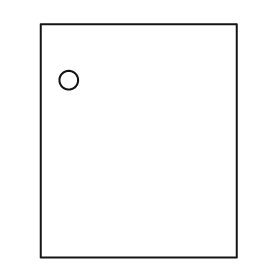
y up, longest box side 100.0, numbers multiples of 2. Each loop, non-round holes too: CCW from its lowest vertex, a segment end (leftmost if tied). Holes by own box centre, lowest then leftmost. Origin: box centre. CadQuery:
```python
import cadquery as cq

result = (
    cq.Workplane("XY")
    .moveTo(-42.0, -50.0)
    .lineTo(42.0, -50.0)
    .lineTo(42.0, 50.0)
    .lineTo(-42.0, 50.0)
    .close()
    .moveTo(-30.0, 26.0)
    .circle(4.0)
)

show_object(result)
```